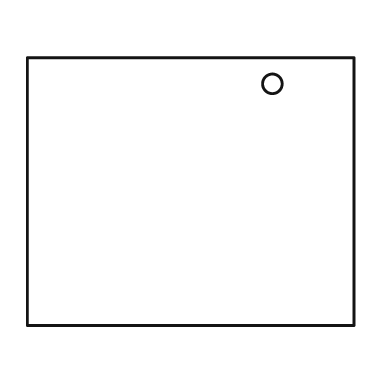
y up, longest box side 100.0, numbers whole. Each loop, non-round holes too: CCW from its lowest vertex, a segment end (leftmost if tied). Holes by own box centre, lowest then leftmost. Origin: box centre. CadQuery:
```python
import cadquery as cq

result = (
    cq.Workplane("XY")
    .moveTo(-50.0, -41.0)
    .lineTo(50.0, -41.0)
    .lineTo(50.0, 41.0)
    .lineTo(-50.0, 41.0)
    .close()
    .moveTo(25.0, 33.0)
    .circle(3.0)
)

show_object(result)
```